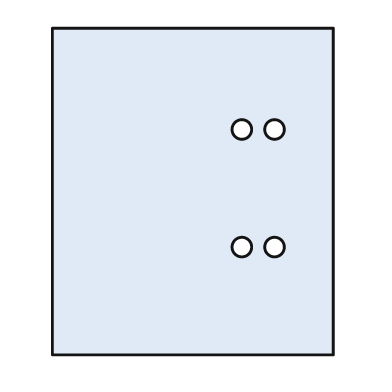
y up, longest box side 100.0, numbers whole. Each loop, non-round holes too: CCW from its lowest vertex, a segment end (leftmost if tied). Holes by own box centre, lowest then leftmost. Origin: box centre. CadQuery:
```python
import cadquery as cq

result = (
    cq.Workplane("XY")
    .moveTo(-43.0, -50.0)
    .lineTo(43.0, -50.0)
    .lineTo(43.0, 50.0)
    .lineTo(-43.0, 50.0)
    .close()
    .moveTo(15.0, -17.0)
    .circle(3.0)
    .moveTo(25.0, -17.0)
    .circle(3.0)
    .moveTo(15.0, 19.0)
    .circle(3.0)
    .moveTo(25.0, 19.0)
    .circle(3.0)
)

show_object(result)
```